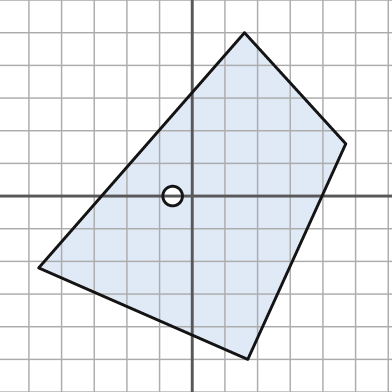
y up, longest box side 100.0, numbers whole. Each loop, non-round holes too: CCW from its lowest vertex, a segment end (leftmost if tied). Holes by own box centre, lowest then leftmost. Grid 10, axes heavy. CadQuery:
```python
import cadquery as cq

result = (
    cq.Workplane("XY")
    .moveTo(17.0, -50.0)
    .lineTo(47.0, 16.0)
    .lineTo(16.0, 50.0)
    .lineTo(-47.0, -22.0)
    .close()
    .moveTo(-6.0, 0.0)
    .circle(3.0)
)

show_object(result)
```